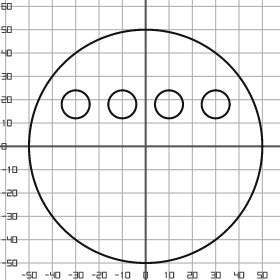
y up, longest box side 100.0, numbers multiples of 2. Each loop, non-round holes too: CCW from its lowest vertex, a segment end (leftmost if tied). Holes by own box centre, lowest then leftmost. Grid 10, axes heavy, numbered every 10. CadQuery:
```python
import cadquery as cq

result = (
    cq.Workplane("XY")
    .moveTo(0.0, 0.0)
    .circle(50.0)
    .moveTo(-30.0, 18.0)
    .circle(6.0)
    .moveTo(-10.0, 18.0)
    .circle(6.0)
    .moveTo(10.0, 18.0)
    .circle(6.0)
    .moveTo(30.0, 18.0)
    .circle(6.0)
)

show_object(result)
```